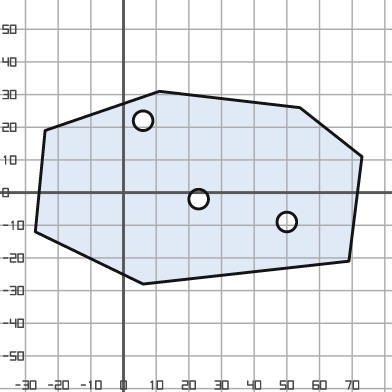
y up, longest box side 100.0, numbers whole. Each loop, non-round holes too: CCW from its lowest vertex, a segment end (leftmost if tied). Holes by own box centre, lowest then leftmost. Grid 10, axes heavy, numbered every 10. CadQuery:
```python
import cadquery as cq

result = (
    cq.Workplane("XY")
    .moveTo(6.0, -28.0)
    .lineTo(69.0, -21.0)
    .lineTo(73.0, 11.0)
    .lineTo(54.0, 26.0)
    .lineTo(11.0, 31.0)
    .lineTo(-24.0, 19.0)
    .lineTo(-27.0, -12.0)
    .close()
    .moveTo(50.0, -9.0)
    .circle(3.0)
    .moveTo(23.0, -2.0)
    .circle(3.0)
    .moveTo(6.0, 22.0)
    .circle(3.0)
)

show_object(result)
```